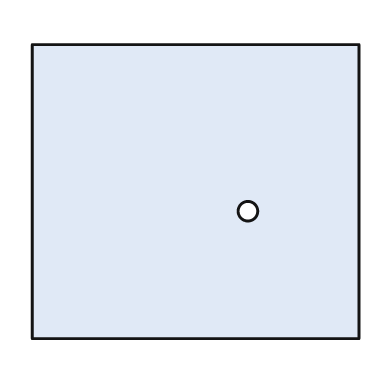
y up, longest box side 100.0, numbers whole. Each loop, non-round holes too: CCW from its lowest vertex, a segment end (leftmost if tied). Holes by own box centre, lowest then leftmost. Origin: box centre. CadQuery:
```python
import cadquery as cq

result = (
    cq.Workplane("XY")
    .moveTo(-50.0, -45.0)
    .lineTo(50.0, -45.0)
    .lineTo(50.0, 45.0)
    .lineTo(-50.0, 45.0)
    .close()
    .moveTo(16.0, -6.0)
    .circle(3.0)
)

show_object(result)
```